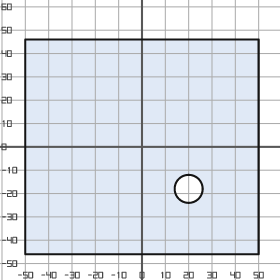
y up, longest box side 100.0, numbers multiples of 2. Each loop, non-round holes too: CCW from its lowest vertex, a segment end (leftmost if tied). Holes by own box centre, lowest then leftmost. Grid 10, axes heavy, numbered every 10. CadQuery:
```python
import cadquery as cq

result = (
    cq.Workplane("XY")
    .moveTo(-50.0, -46.0)
    .lineTo(50.0, -46.0)
    .lineTo(50.0, 46.0)
    .lineTo(-50.0, 46.0)
    .close()
    .moveTo(20.0, -18.0)
    .circle(6.0)
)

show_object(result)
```